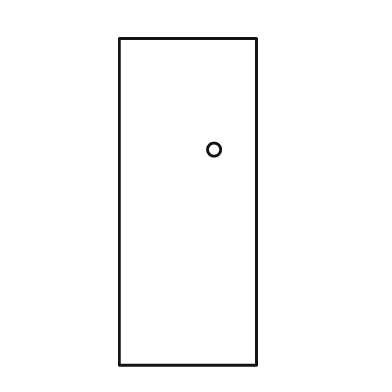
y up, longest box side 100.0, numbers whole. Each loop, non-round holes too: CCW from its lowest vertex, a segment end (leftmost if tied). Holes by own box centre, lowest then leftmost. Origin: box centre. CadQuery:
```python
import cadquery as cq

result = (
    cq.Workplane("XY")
    .moveTo(-21.0, -50.0)
    .lineTo(21.0, -50.0)
    .lineTo(21.0, 50.0)
    .lineTo(-21.0, 50.0)
    .close()
    .moveTo(8.0, 16.0)
    .circle(2.0)
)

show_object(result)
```